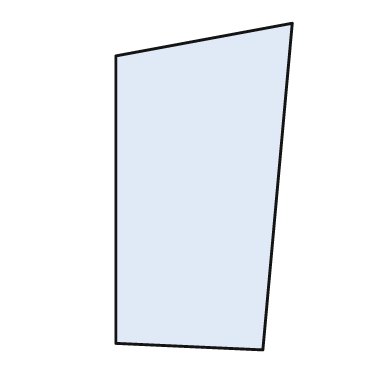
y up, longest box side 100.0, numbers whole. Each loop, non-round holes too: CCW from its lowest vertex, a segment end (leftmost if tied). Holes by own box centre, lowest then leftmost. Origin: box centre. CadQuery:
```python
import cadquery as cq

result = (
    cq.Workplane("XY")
    .moveTo(18.0, -50.0)
    .lineTo(27.0, 50.0)
    .lineTo(-27.0, 40.0)
    .lineTo(-27.0, -48.0)
    .close()
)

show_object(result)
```